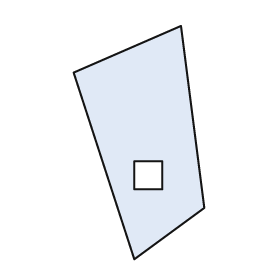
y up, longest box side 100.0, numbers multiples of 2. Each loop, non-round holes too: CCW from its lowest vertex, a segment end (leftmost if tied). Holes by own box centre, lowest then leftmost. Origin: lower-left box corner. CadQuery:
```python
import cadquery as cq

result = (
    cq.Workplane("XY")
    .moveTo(26.0, 0.0)
    .lineTo(56.0, 22.0)
    .lineTo(46.0, 100.0)
    .lineTo(0.0, 80.0)
    .close()
    .moveTo(26.0, 30.0)
    .lineTo(38.0, 30.0)
    .lineTo(38.0, 42.0)
    .lineTo(26.0, 42.0)
    .close()
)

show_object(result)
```